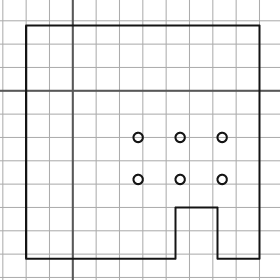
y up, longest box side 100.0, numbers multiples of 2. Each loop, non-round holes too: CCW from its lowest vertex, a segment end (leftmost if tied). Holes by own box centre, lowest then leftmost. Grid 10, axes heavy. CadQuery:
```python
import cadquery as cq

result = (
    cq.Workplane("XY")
    .moveTo(-20.0, -72.0)
    .lineTo(44.0, -72.0)
    .lineTo(44.0, -50.0)
    .lineTo(62.0, -50.0)
    .lineTo(62.0, -72.0)
    .lineTo(80.0, -72.0)
    .lineTo(80.0, 28.0)
    .lineTo(-20.0, 28.0)
    .close()
    .moveTo(28.0, -38.0)
    .circle(2.0)
    .moveTo(46.0, -38.0)
    .circle(2.0)
    .moveTo(64.0, -38.0)
    .circle(2.0)
    .moveTo(28.0, -20.0)
    .circle(2.0)
    .moveTo(46.0, -20.0)
    .circle(2.0)
    .moveTo(64.0, -20.0)
    .circle(2.0)
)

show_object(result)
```